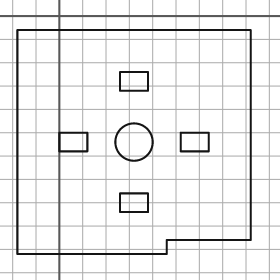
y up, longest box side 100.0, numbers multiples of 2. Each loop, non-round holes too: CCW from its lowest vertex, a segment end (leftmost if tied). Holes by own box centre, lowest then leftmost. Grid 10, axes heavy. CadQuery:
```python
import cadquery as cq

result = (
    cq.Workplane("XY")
    .moveTo(-18.0, -102.0)
    .lineTo(46.0, -102.0)
    .lineTo(46.0, -96.0)
    .lineTo(82.0, -96.0)
    .lineTo(82.0, -6.0)
    .lineTo(-18.0, -6.0)
    .close()
    .moveTo(26.0, -84.0)
    .lineTo(38.0, -84.0)
    .lineTo(38.0, -76.0)
    .lineTo(26.0, -76.0)
    .close()
    .moveTo(0.0, -58.0)
    .lineTo(12.0, -58.0)
    .lineTo(12.0, -50.0)
    .lineTo(0.0, -50.0)
    .close()
    .moveTo(32.0, -54.0)
    .circle(8.0)
    .moveTo(52.0, -58.0)
    .lineTo(64.0, -58.0)
    .lineTo(64.0, -50.0)
    .lineTo(52.0, -50.0)
    .close()
    .moveTo(26.0, -32.0)
    .lineTo(38.0, -32.0)
    .lineTo(38.0, -24.0)
    .lineTo(26.0, -24.0)
    .close()
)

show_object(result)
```